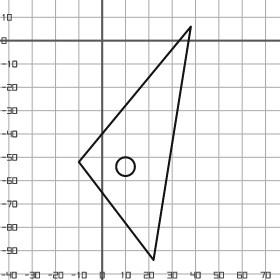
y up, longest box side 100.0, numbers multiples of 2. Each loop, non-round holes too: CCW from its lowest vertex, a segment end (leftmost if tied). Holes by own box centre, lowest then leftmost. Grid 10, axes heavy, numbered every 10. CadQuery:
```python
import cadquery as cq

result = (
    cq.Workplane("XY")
    .moveTo(22.0, -94.0)
    .lineTo(38.0, 6.0)
    .lineTo(-10.0, -52.0)
    .close()
    .moveTo(10.0, -54.0)
    .circle(4.0)
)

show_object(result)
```